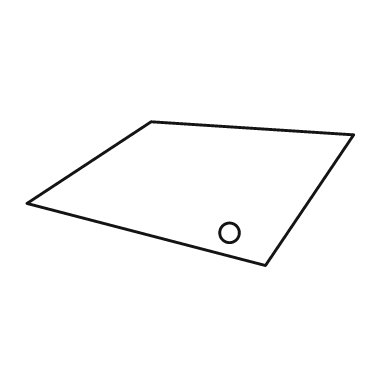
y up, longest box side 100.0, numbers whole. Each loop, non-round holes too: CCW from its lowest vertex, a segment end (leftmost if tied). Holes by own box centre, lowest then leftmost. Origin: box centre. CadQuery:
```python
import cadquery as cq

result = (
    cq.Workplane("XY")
    .moveTo(23.0, -22.0)
    .lineTo(50.0, 18.0)
    .lineTo(-12.0, 22.0)
    .lineTo(-50.0, -3.0)
    .close()
    .moveTo(12.0, -12.0)
    .circle(3.0)
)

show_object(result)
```